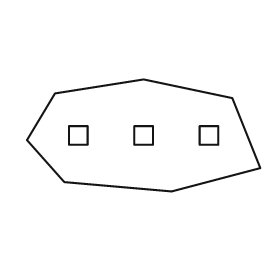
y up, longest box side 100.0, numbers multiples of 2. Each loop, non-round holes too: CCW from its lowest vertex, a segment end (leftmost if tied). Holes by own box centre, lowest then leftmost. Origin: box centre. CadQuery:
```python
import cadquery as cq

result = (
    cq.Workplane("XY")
    .moveTo(12.0, -24.0)
    .lineTo(50.0, -14.0)
    .lineTo(38.0, 16.0)
    .lineTo(0.0, 24.0)
    .lineTo(-38.0, 18.0)
    .lineTo(-50.0, -2.0)
    .lineTo(-34.0, -20.0)
    .close()
    .moveTo(-32.0, -4.0)
    .lineTo(-24.0, -4.0)
    .lineTo(-24.0, 4.0)
    .lineTo(-32.0, 4.0)
    .close()
    .moveTo(-4.0, -4.0)
    .lineTo(4.0, -4.0)
    .lineTo(4.0, 4.0)
    .lineTo(-4.0, 4.0)
    .close()
    .moveTo(24.0, -4.0)
    .lineTo(32.0, -4.0)
    .lineTo(32.0, 4.0)
    .lineTo(24.0, 4.0)
    .close()
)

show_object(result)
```